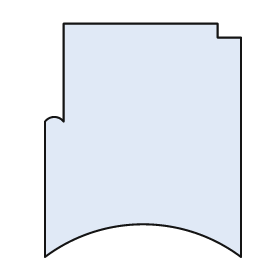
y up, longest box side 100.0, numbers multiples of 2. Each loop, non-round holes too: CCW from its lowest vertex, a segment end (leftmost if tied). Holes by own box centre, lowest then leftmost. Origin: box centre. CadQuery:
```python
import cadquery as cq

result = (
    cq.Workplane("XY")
    .moveTo(-42.0, -50.0)
    .threePointArc((0.0, -36.0), (42.0, -50.0))
    .lineTo(42.0, 44.0)
    .lineTo(32.0, 44.0)
    .lineTo(32.0, 50.0)
    .lineTo(-34.0, 50.0)
    .lineTo(-34.0, 8.0)
    .threePointArc((-38.0, 10.0), (-42.0, 8.0))
    .close()
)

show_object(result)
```